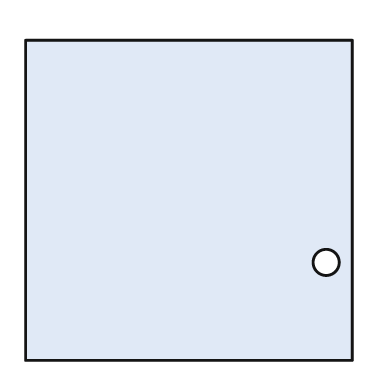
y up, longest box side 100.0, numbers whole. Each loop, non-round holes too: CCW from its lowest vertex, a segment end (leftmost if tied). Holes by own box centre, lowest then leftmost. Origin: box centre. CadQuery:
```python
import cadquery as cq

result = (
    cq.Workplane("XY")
    .moveTo(-50.0, -49.0)
    .lineTo(50.0, -49.0)
    .lineTo(50.0, 49.0)
    .lineTo(-50.0, 49.0)
    .close()
    .moveTo(42.0, -19.0)
    .circle(4.0)
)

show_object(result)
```